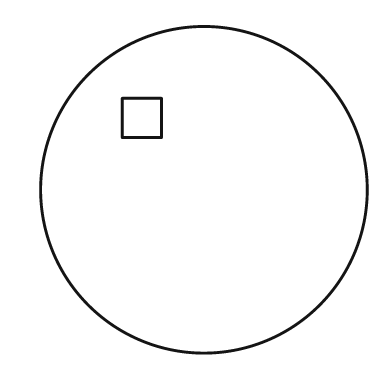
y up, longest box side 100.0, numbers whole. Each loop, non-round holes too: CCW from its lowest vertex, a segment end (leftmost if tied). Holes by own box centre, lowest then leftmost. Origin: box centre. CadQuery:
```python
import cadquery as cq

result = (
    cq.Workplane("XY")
    .moveTo(0.0, 0.0)
    .circle(50.0)
    .moveTo(-25.0, 16.0)
    .lineTo(-13.0, 16.0)
    .lineTo(-13.0, 28.0)
    .lineTo(-25.0, 28.0)
    .close()
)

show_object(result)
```